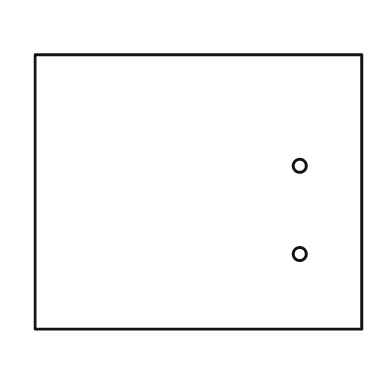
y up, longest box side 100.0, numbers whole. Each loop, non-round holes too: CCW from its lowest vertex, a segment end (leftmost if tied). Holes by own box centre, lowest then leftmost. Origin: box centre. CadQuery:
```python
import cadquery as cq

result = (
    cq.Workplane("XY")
    .moveTo(-50.0, -42.0)
    .lineTo(50.0, -42.0)
    .lineTo(50.0, 42.0)
    .lineTo(-50.0, 42.0)
    .close()
    .moveTo(31.0, -19.0)
    .circle(2.0)
    .moveTo(31.0, 8.0)
    .circle(2.0)
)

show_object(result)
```